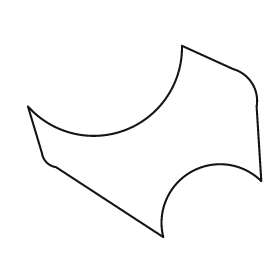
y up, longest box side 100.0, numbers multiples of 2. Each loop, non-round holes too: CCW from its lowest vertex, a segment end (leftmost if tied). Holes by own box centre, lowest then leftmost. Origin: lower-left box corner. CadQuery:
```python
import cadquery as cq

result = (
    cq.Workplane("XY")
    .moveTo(58.0, 0.0)
    .threePointArc((70.0, 28.0), (100.0, 24.0))
    .lineTo(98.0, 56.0)
    .threePointArc((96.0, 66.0), (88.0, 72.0))
    .lineTo(66.0, 82.0)
    .threePointArc((42.0, 46.0), (0.0, 56.0))
    .lineTo(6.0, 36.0)
    .threePointArc((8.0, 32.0), (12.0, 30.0))
    .close()
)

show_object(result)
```